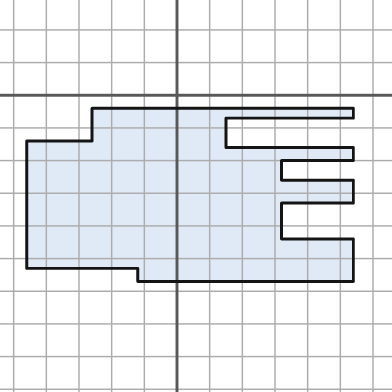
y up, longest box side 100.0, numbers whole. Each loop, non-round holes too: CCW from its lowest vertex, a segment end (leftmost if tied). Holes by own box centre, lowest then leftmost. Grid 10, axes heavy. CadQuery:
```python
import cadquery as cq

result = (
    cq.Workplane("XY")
    .moveTo(-12.0, -57.0)
    .lineTo(54.0, -57.0)
    .lineTo(54.0, -44.0)
    .lineTo(32.0, -44.0)
    .lineTo(32.0, -33.0)
    .lineTo(54.0, -33.0)
    .lineTo(54.0, -26.0)
    .lineTo(32.0, -26.0)
    .lineTo(32.0, -20.0)
    .lineTo(54.0, -20.0)
    .lineTo(54.0, -16.0)
    .lineTo(15.0, -16.0)
    .lineTo(15.0, -7.0)
    .lineTo(54.0, -7.0)
    .lineTo(54.0, -4.0)
    .lineTo(-26.0, -4.0)
    .lineTo(-26.0, -14.0)
    .lineTo(-46.0, -14.0)
    .lineTo(-46.0, -53.0)
    .lineTo(-12.0, -53.0)
    .close()
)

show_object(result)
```